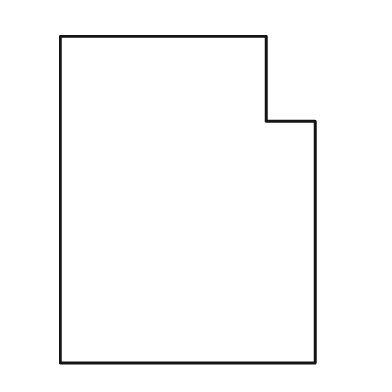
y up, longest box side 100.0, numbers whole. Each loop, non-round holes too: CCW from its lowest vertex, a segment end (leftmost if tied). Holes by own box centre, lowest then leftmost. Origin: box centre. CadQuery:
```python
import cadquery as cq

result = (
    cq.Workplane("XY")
    .moveTo(-39.0, -50.0)
    .lineTo(39.0, -50.0)
    .lineTo(39.0, 24.0)
    .lineTo(24.0, 24.0)
    .lineTo(24.0, 50.0)
    .lineTo(-39.0, 50.0)
    .close()
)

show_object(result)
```